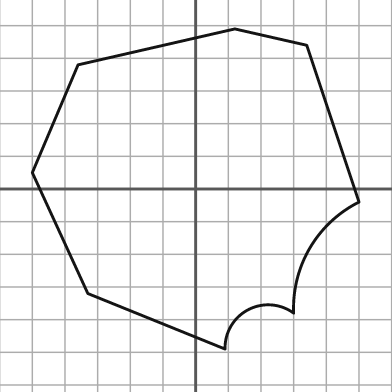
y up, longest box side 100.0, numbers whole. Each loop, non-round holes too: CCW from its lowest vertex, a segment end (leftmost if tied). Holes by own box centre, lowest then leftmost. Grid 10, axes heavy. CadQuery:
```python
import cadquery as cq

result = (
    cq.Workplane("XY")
    .moveTo(9.0, -49.0)
    .threePointArc((16.0, -37.0), (30.0, -38.0))
    .threePointArc((35.0, -18.0), (50.0, -4.0))
    .lineTo(34.0, 44.0)
    .lineTo(12.0, 49.0)
    .lineTo(-36.0, 38.0)
    .lineTo(-50.0, 5.0)
    .lineTo(-33.0, -32.0)
    .close()
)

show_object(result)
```